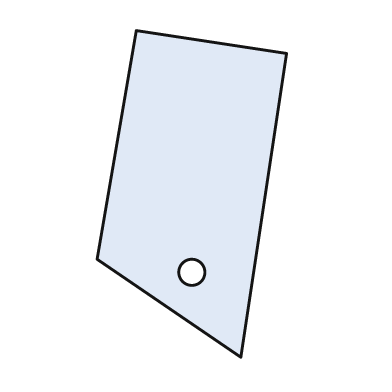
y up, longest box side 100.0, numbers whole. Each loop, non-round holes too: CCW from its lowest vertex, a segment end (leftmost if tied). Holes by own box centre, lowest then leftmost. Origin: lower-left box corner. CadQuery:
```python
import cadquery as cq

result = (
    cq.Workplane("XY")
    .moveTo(44.0, 0.0)
    .lineTo(58.0, 93.0)
    .lineTo(12.0, 100.0)
    .lineTo(0.0, 30.0)
    .close()
    .moveTo(29.0, 26.0)
    .circle(4.0)
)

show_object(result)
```